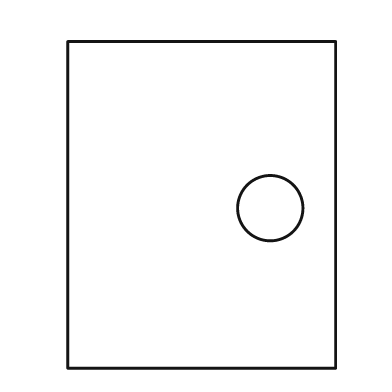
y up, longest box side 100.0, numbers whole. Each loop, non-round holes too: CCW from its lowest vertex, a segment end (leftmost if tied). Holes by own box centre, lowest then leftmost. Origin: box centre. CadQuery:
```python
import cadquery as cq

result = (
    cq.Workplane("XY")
    .moveTo(-41.0, -50.0)
    .lineTo(41.0, -50.0)
    .lineTo(41.0, 50.0)
    .lineTo(-41.0, 50.0)
    .close()
    .moveTo(21.0, -1.0)
    .circle(10.0)
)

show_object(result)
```